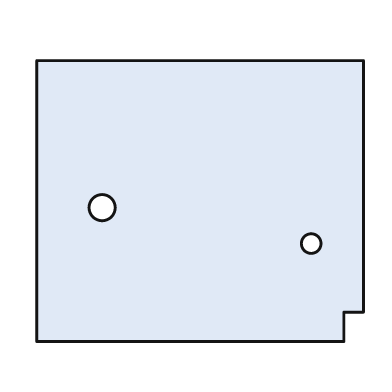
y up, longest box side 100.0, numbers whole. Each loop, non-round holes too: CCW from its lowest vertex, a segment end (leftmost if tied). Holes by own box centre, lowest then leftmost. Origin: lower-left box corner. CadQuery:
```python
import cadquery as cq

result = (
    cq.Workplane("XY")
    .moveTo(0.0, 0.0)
    .lineTo(94.0, 0.0)
    .lineTo(94.0, 9.0)
    .lineTo(100.0, 9.0)
    .lineTo(100.0, 86.0)
    .lineTo(0.0, 86.0)
    .close()
    .moveTo(84.0, 30.0)
    .circle(3.0)
    .moveTo(20.0, 41.0)
    .circle(4.0)
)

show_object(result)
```